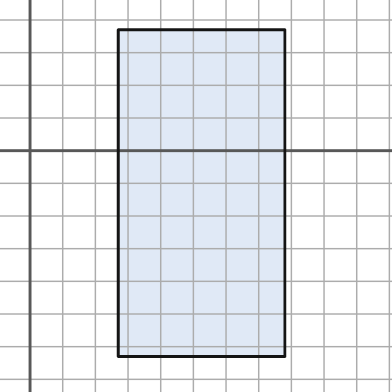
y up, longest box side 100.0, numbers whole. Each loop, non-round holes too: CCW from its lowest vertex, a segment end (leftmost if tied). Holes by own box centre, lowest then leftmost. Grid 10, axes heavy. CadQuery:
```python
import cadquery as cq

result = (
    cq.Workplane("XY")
    .moveTo(27.0, -63.0)
    .lineTo(78.0, -63.0)
    .lineTo(78.0, 37.0)
    .lineTo(27.0, 37.0)
    .close()
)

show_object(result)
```